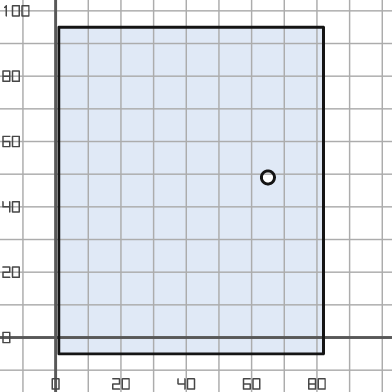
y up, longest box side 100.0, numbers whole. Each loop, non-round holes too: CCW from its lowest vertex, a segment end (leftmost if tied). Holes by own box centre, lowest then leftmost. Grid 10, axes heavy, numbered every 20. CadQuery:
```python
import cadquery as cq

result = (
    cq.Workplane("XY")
    .moveTo(1.0, -5.0)
    .lineTo(82.0, -5.0)
    .lineTo(82.0, 95.0)
    .lineTo(1.0, 95.0)
    .close()
    .moveTo(65.0, 49.0)
    .circle(2.0)
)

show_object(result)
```